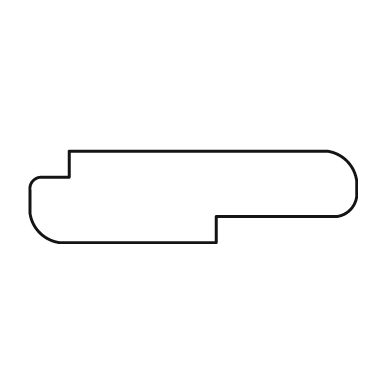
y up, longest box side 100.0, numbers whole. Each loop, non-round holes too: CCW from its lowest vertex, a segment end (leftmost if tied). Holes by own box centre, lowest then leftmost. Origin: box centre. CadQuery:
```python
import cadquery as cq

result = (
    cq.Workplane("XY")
    .moveTo(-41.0, -14.0)
    .lineTo(7.0, -14.0)
    .lineTo(7.0, -6.0)
    .lineTo(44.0, -6.0)
    .threePointArc((48.0, -4.0), (50.0, 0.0))
    .lineTo(50.0, 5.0)
    .threePointArc((47.0, 11.0), (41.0, 14.0))
    .lineTo(-38.0, 14.0)
    .lineTo(-38.0, 6.0)
    .lineTo(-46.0, 6.0)
    .threePointArc((-49.0, 5.0), (-50.0, 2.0))
    .lineTo(-50.0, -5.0)
    .threePointArc((-47.0, -11.0), (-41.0, -14.0))
    .close()
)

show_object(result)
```